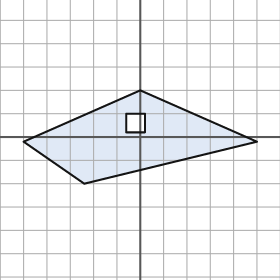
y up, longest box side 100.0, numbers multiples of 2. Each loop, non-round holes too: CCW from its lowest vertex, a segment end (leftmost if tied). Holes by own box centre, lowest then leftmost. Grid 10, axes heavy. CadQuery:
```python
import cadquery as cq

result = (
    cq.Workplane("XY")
    .moveTo(-24.0, -20.0)
    .lineTo(50.0, -2.0)
    .lineTo(0.0, 20.0)
    .lineTo(-50.0, -2.0)
    .close()
    .moveTo(-6.0, 2.0)
    .lineTo(2.0, 2.0)
    .lineTo(2.0, 10.0)
    .lineTo(-6.0, 10.0)
    .close()
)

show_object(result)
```